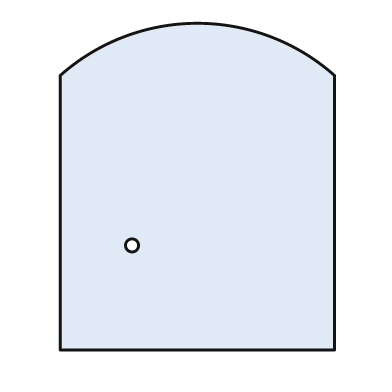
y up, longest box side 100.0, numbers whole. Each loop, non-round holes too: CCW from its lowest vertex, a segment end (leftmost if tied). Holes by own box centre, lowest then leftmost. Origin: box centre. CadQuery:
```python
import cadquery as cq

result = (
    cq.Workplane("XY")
    .moveTo(-42.0, -50.0)
    .lineTo(42.0, -50.0)
    .lineTo(42.0, 34.0)
    .threePointArc((0.0, 50.0), (-42.0, 34.0))
    .close()
    .moveTo(-20.0, -18.0)
    .circle(2.0)
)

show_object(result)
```